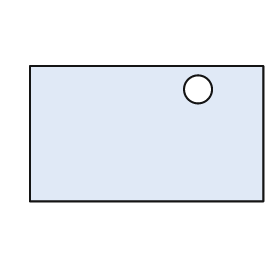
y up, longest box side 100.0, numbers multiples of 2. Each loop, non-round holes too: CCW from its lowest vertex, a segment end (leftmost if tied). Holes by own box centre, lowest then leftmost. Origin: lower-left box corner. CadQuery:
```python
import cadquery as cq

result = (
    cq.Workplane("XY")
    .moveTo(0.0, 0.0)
    .lineTo(100.0, 0.0)
    .lineTo(100.0, 58.0)
    .lineTo(0.0, 58.0)
    .close()
    .moveTo(72.0, 48.0)
    .circle(6.0)
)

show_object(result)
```